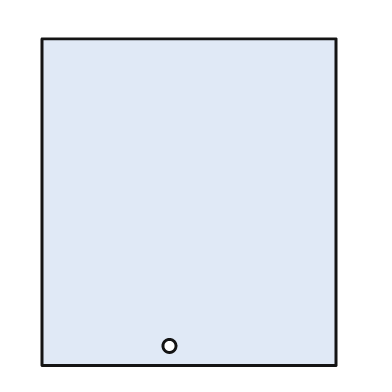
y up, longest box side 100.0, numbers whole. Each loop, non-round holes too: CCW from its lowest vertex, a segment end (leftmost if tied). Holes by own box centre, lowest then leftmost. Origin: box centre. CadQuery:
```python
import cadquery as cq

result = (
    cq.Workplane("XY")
    .moveTo(-45.0, -50.0)
    .lineTo(45.0, -50.0)
    .lineTo(45.0, 50.0)
    .lineTo(-45.0, 50.0)
    .close()
    .moveTo(-6.0, -44.0)
    .circle(2.0)
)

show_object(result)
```